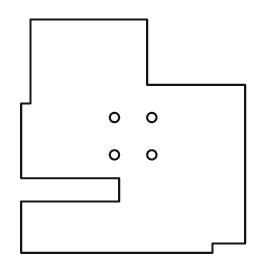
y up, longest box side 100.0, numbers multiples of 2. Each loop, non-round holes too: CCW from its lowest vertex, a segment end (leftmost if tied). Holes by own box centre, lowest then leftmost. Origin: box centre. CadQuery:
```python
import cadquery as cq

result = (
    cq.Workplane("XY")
    .moveTo(-48.0, -50.0)
    .lineTo(34.0, -50.0)
    .lineTo(34.0, -46.0)
    .lineTo(48.0, -46.0)
    .lineTo(48.0, 22.0)
    .lineTo(6.0, 22.0)
    .lineTo(6.0, 50.0)
    .lineTo(-44.0, 50.0)
    .lineTo(-44.0, 14.0)
    .lineTo(-48.0, 14.0)
    .lineTo(-48.0, -18.0)
    .lineTo(-6.0, -18.0)
    .lineTo(-6.0, -28.0)
    .lineTo(-48.0, -28.0)
    .close()
    .moveTo(-8.0, -8.0)
    .circle(2.0)
    .moveTo(8.0, -8.0)
    .circle(2.0)
    .moveTo(-8.0, 8.0)
    .circle(2.0)
    .moveTo(8.0, 8.0)
    .circle(2.0)
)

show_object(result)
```